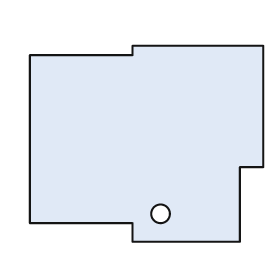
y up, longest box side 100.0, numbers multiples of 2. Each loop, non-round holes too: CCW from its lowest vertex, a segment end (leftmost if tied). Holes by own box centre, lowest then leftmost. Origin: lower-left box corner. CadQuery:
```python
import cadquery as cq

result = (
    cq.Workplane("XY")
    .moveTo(44.0, 0.0)
    .lineTo(90.0, 0.0)
    .lineTo(90.0, 32.0)
    .lineTo(100.0, 32.0)
    .lineTo(100.0, 84.0)
    .lineTo(44.0, 84.0)
    .lineTo(44.0, 80.0)
    .lineTo(0.0, 80.0)
    .lineTo(0.0, 8.0)
    .lineTo(44.0, 8.0)
    .close()
    .moveTo(56.0, 12.0)
    .circle(4.0)
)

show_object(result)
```